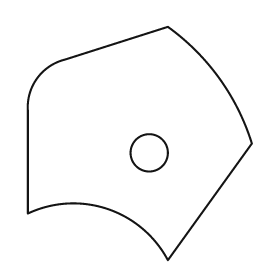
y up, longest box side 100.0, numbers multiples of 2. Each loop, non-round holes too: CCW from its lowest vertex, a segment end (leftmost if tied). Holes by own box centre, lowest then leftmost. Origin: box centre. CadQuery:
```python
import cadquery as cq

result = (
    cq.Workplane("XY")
    .moveTo(12.0, -50.0)
    .lineTo(48.0, 0.0)
    .threePointArc((34.0, 28.0), (12.0, 50.0))
    .lineTo(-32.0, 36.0)
    .threePointArc((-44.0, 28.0), (-48.0, 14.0))
    .lineTo(-48.0, -30.0)
    .threePointArc((-14.0, -28.0), (12.0, -50.0))
    .close()
    .moveTo(4.0, -4.0)
    .circle(8.0)
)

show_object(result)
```